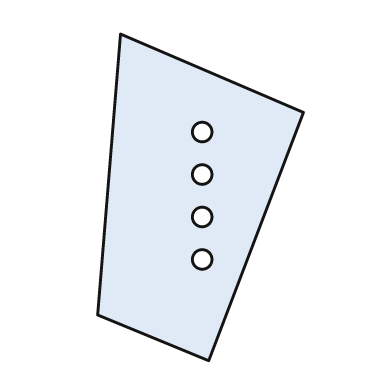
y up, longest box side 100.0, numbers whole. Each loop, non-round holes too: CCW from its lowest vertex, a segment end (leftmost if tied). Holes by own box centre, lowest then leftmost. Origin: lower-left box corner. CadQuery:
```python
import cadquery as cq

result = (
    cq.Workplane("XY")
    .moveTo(34.0, 0.0)
    .lineTo(63.0, 76.0)
    .lineTo(7.0, 100.0)
    .lineTo(0.0, 14.0)
    .close()
    .moveTo(32.0, 31.0)
    .circle(3.0)
    .moveTo(32.0, 44.0)
    .circle(3.0)
    .moveTo(32.0, 57.0)
    .circle(3.0)
    .moveTo(32.0, 70.0)
    .circle(3.0)
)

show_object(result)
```